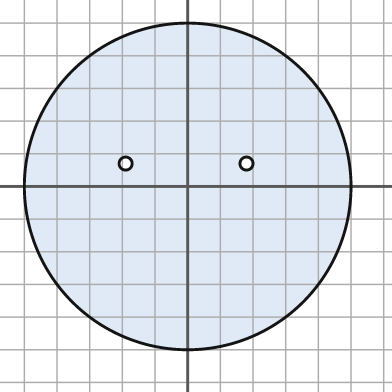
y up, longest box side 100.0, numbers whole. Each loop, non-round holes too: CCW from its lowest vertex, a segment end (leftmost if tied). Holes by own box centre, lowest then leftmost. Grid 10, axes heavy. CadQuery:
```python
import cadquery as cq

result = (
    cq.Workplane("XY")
    .moveTo(0.0, 0.0)
    .circle(50.0)
    .moveTo(-19.0, 7.0)
    .circle(2.0)
    .moveTo(18.0, 7.0)
    .circle(2.0)
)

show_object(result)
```